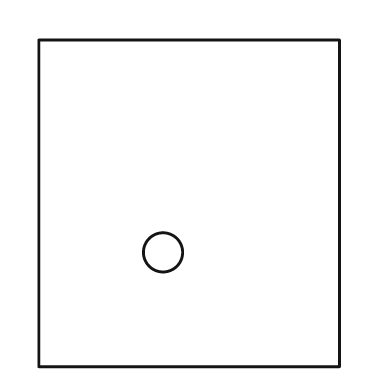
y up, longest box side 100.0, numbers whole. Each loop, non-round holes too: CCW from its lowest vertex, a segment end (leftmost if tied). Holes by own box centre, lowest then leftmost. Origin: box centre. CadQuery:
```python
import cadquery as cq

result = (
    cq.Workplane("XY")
    .moveTo(-46.0, -50.0)
    .lineTo(46.0, -50.0)
    .lineTo(46.0, 50.0)
    .lineTo(-46.0, 50.0)
    .close()
    .moveTo(-8.0, -15.0)
    .circle(6.0)
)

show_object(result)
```